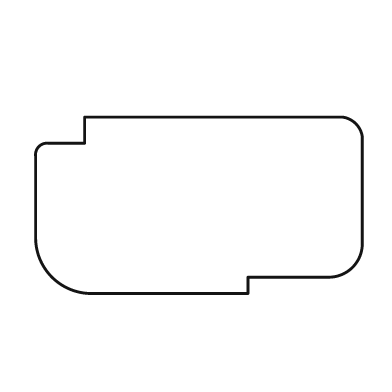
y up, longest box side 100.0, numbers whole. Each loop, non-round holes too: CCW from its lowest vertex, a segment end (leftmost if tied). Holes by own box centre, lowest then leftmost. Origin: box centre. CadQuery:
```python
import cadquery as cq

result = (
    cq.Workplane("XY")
    .moveTo(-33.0, -27.0)
    .lineTo(15.0, -27.0)
    .lineTo(15.0, -22.0)
    .lineTo(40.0, -22.0)
    .threePointArc((47.0, -19.0), (50.0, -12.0))
    .lineTo(50.0, 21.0)
    .threePointArc((48.0, 25.0), (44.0, 27.0))
    .lineTo(-35.0, 27.0)
    .lineTo(-35.0, 19.0)
    .lineTo(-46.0, 19.0)
    .threePointArc((-49.0, 18.0), (-50.0, 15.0))
    .lineTo(-50.0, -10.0)
    .threePointArc((-45.0, -22.0), (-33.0, -27.0))
    .close()
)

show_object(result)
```